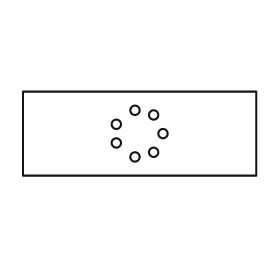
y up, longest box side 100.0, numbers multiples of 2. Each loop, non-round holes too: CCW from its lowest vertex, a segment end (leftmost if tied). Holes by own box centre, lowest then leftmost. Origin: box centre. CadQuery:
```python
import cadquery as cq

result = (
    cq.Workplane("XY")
    .moveTo(-50.0, -18.0)
    .lineTo(50.0, -18.0)
    .lineTo(50.0, 18.0)
    .lineTo(-50.0, 18.0)
    .close()
    .moveTo(-2.0, -10.0)
    .circle(2.0)
    .moveTo(6.0, -8.0)
    .circle(2.0)
    .moveTo(-10.0, -4.0)
    .circle(2.0)
    .moveTo(10.0, 0.0)
    .circle(2.0)
    .moveTo(-10.0, 4.0)
    .circle(2.0)
    .moveTo(6.0, 8.0)
    .circle(2.0)
    .moveTo(-2.0, 10.0)
    .circle(2.0)
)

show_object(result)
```